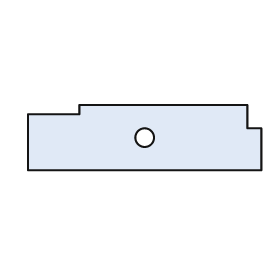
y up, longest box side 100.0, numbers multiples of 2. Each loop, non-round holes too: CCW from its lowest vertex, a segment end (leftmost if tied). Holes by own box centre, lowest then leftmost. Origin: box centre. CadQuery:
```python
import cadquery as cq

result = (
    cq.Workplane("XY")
    .moveTo(-50.0, -14.0)
    .lineTo(50.0, -14.0)
    .lineTo(50.0, 4.0)
    .lineTo(44.0, 4.0)
    .lineTo(44.0, 14.0)
    .lineTo(-28.0, 14.0)
    .lineTo(-28.0, 10.0)
    .lineTo(-50.0, 10.0)
    .close()
    .moveTo(0.0, 0.0)
    .circle(4.0)
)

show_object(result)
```